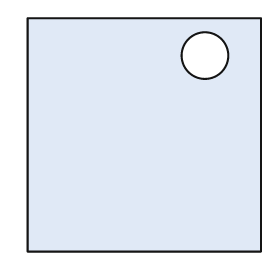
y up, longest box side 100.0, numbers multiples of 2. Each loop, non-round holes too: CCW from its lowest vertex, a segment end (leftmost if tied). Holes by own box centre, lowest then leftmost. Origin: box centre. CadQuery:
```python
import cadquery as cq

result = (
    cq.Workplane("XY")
    .moveTo(-50.0, -50.0)
    .lineTo(50.0, -50.0)
    .lineTo(50.0, 50.0)
    .lineTo(-50.0, 50.0)
    .close()
    .moveTo(26.0, 34.0)
    .circle(10.0)
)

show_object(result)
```